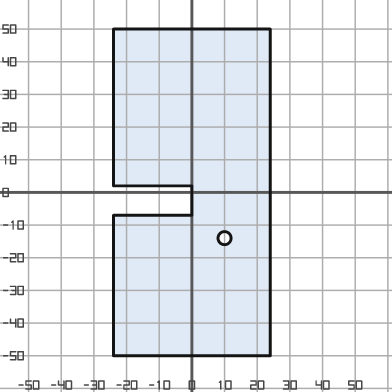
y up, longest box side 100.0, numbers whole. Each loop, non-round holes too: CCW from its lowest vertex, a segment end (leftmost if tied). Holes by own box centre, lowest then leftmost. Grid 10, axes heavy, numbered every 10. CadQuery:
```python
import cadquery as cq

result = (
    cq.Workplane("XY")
    .moveTo(-24.0, -50.0)
    .lineTo(24.0, -50.0)
    .lineTo(24.0, 50.0)
    .lineTo(-24.0, 50.0)
    .lineTo(-24.0, 2.0)
    .lineTo(0.0, 2.0)
    .lineTo(0.0, -7.0)
    .lineTo(-24.0, -7.0)
    .close()
    .moveTo(10.0, -14.0)
    .circle(2.0)
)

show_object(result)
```